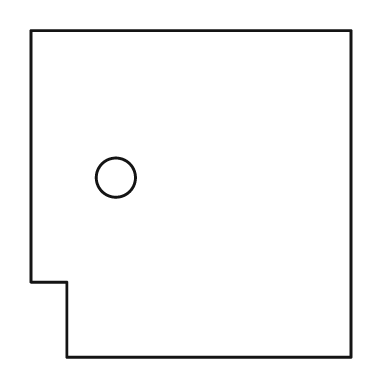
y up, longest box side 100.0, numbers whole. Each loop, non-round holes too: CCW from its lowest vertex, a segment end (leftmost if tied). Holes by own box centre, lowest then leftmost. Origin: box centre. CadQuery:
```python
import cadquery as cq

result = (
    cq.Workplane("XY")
    .moveTo(-38.0, -50.0)
    .lineTo(49.0, -50.0)
    .lineTo(49.0, 50.0)
    .lineTo(-49.0, 50.0)
    .lineTo(-49.0, -27.0)
    .lineTo(-38.0, -27.0)
    .close()
    .moveTo(-23.0, 5.0)
    .circle(6.0)
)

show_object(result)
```